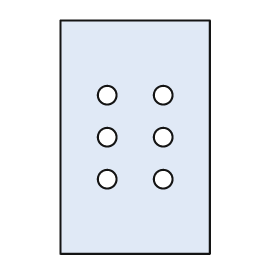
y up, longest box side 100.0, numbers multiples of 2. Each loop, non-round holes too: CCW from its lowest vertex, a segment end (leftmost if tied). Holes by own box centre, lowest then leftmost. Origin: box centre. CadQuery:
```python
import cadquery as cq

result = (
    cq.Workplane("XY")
    .moveTo(-32.0, -50.0)
    .lineTo(32.0, -50.0)
    .lineTo(32.0, 50.0)
    .lineTo(-32.0, 50.0)
    .close()
    .moveTo(-12.0, -18.0)
    .circle(4.0)
    .moveTo(12.0, -18.0)
    .circle(4.0)
    .moveTo(-12.0, 0.0)
    .circle(4.0)
    .moveTo(12.0, 0.0)
    .circle(4.0)
    .moveTo(-12.0, 18.0)
    .circle(4.0)
    .moveTo(12.0, 18.0)
    .circle(4.0)
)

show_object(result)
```